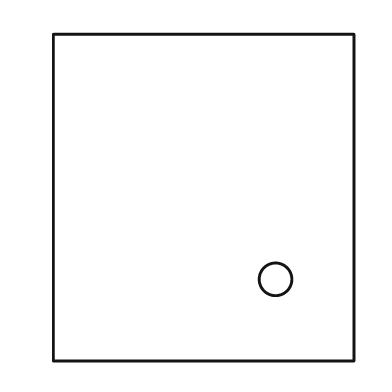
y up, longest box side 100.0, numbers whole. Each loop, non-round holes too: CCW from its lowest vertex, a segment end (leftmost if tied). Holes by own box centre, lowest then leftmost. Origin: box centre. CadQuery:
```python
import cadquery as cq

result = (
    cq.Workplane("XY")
    .moveTo(-46.0, -50.0)
    .lineTo(46.0, -50.0)
    .lineTo(46.0, 50.0)
    .lineTo(-46.0, 50.0)
    .close()
    .moveTo(22.0, -25.0)
    .circle(5.0)
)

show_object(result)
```